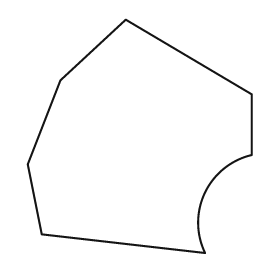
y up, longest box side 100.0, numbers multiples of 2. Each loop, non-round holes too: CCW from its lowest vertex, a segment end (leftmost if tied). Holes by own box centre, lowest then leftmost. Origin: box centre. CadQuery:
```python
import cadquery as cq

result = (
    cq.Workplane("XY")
    .moveTo(28.0, -50.0)
    .threePointArc((28.0, -24.0), (48.0, -8.0))
    .lineTo(48.0, 18.0)
    .lineTo(-6.0, 50.0)
    .lineTo(-34.0, 24.0)
    .lineTo(-48.0, -12.0)
    .lineTo(-42.0, -42.0)
    .close()
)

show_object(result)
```